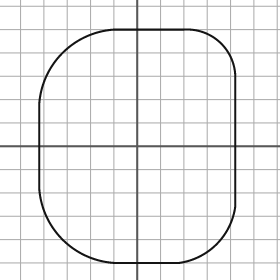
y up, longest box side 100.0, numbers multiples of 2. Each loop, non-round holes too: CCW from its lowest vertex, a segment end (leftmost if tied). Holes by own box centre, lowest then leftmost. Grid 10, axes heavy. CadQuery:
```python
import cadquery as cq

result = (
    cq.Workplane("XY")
    .moveTo(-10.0, -50.0)
    .lineTo(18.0, -50.0)
    .threePointArc((34.0, -42.0), (42.0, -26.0))
    .lineTo(42.0, 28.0)
    .threePointArc((36.0, 44.0), (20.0, 50.0))
    .lineTo(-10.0, 50.0)
    .threePointArc((-32.0, 40.0), (-42.0, 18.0))
    .lineTo(-42.0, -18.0)
    .threePointArc((-32.0, -40.0), (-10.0, -50.0))
    .close()
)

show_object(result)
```